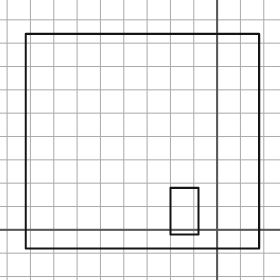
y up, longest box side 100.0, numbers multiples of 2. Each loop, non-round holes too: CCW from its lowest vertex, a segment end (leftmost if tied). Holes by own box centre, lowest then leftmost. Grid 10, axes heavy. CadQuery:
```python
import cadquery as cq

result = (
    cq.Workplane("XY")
    .moveTo(-82.0, -8.0)
    .lineTo(18.0, -8.0)
    .lineTo(18.0, 84.0)
    .lineTo(-82.0, 84.0)
    .close()
    .moveTo(-20.0, -2.0)
    .lineTo(-8.0, -2.0)
    .lineTo(-8.0, 18.0)
    .lineTo(-20.0, 18.0)
    .close()
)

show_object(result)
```